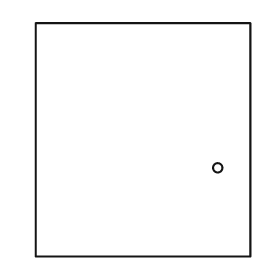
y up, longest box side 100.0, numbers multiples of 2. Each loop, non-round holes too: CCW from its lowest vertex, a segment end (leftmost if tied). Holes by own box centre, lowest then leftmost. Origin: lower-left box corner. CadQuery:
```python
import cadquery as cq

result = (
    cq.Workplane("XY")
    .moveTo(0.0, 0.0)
    .lineTo(92.0, 0.0)
    .lineTo(92.0, 100.0)
    .lineTo(0.0, 100.0)
    .close()
    .moveTo(78.0, 38.0)
    .circle(2.0)
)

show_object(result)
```